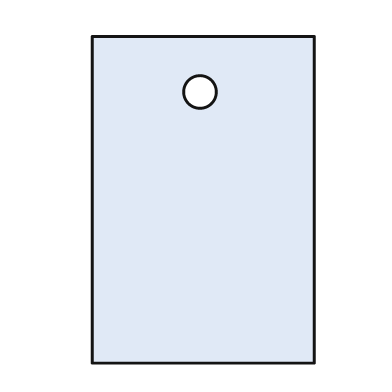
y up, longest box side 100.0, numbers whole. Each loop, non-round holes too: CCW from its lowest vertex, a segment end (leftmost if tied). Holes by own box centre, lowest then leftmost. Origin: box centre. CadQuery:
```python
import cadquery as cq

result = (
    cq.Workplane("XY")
    .moveTo(-34.0, -50.0)
    .lineTo(34.0, -50.0)
    .lineTo(34.0, 50.0)
    .lineTo(-34.0, 50.0)
    .close()
    .moveTo(-1.0, 33.0)
    .circle(5.0)
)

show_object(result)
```